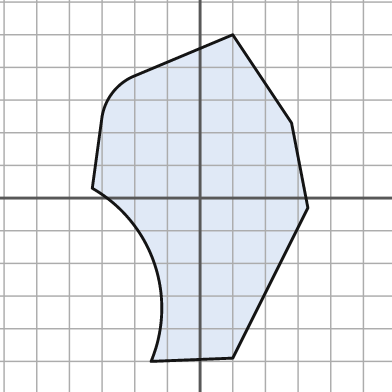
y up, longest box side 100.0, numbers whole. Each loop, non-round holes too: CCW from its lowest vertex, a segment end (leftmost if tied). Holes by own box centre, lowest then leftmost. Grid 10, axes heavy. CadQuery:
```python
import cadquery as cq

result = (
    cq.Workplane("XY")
    .moveTo(-15.0, -50.0)
    .lineTo(10.0, -49.0)
    .lineTo(33.0, -3.0)
    .lineTo(28.0, 23.0)
    .lineTo(10.0, 50.0)
    .lineTo(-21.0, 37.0)
    .threePointArc((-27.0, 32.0), (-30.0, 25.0))
    .lineTo(-33.0, 3.0)
    .threePointArc((-14.0, -20.0), (-15.0, -50.0))
    .close()
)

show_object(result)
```